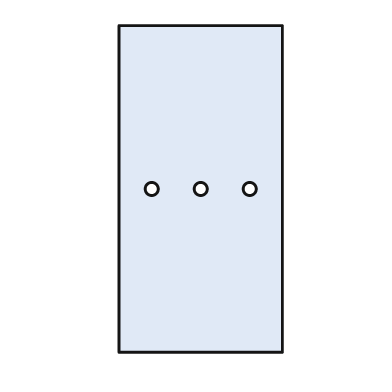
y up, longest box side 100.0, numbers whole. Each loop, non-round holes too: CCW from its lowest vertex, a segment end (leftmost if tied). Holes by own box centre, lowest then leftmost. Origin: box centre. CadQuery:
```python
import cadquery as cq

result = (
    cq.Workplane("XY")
    .moveTo(-25.0, -50.0)
    .lineTo(25.0, -50.0)
    .lineTo(25.0, 50.0)
    .lineTo(-25.0, 50.0)
    .close()
    .moveTo(-15.0, 0.0)
    .circle(2.0)
    .moveTo(0.0, 0.0)
    .circle(2.0)
    .moveTo(15.0, 0.0)
    .circle(2.0)
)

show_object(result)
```